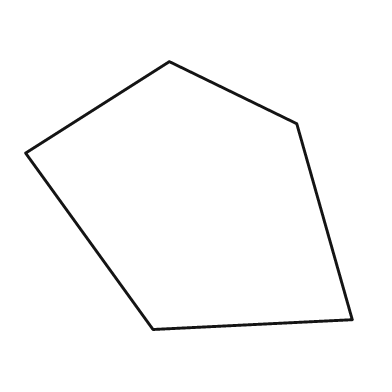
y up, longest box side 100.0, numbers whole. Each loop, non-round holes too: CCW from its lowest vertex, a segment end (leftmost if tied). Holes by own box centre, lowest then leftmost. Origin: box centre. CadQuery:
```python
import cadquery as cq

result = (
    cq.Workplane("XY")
    .moveTo(-11.0, -41.0)
    .lineTo(50.0, -38.0)
    .lineTo(33.0, 22.0)
    .lineTo(-6.0, 41.0)
    .lineTo(-50.0, 13.0)
    .close()
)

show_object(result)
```